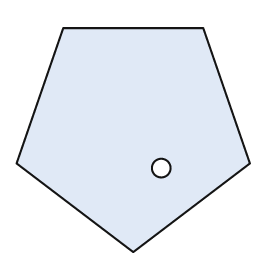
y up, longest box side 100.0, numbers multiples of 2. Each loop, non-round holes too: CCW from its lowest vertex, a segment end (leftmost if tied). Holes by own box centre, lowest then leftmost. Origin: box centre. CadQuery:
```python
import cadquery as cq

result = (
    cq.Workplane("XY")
    .moveTo(0.0, -48.0)
    .lineTo(50.0, -10.0)
    .lineTo(30.0, 48.0)
    .lineTo(-30.0, 48.0)
    .lineTo(-50.0, -10.0)
    .close()
    .moveTo(12.0, -12.0)
    .circle(4.0)
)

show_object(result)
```